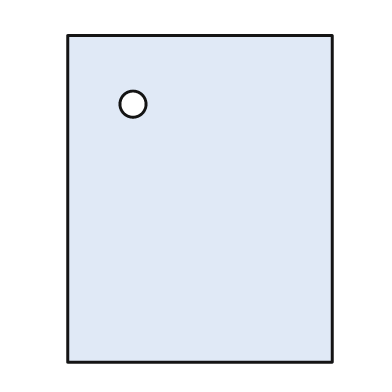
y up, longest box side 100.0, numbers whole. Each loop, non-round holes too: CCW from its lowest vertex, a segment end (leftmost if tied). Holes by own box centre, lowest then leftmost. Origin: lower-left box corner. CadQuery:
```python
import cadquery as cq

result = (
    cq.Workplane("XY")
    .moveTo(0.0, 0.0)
    .lineTo(81.0, 0.0)
    .lineTo(81.0, 100.0)
    .lineTo(0.0, 100.0)
    .close()
    .moveTo(20.0, 79.0)
    .circle(4.0)
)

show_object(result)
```